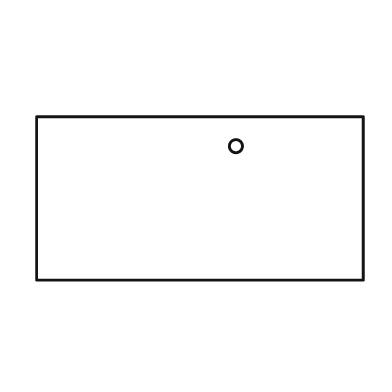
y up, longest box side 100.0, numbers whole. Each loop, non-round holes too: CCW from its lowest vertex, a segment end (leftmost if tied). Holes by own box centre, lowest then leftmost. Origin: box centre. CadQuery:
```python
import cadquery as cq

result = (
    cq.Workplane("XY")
    .moveTo(-50.0, -25.0)
    .lineTo(50.0, -25.0)
    .lineTo(50.0, 25.0)
    .lineTo(-50.0, 25.0)
    .close()
    .moveTo(11.0, 16.0)
    .circle(2.0)
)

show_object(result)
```